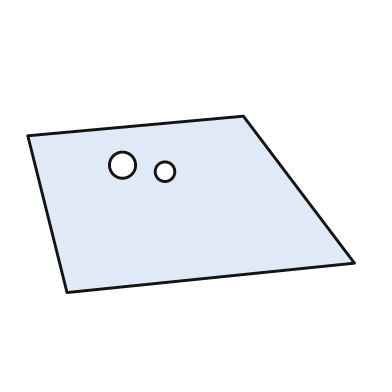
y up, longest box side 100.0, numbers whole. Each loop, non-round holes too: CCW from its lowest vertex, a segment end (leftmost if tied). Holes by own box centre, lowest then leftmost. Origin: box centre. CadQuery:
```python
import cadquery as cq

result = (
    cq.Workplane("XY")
    .moveTo(-38.0, -27.0)
    .lineTo(50.0, -18.0)
    .lineTo(16.0, 27.0)
    .lineTo(-50.0, 21.0)
    .close()
    .moveTo(-8.0, 10.0)
    .circle(3.0)
    .moveTo(-21.0, 12.0)
    .circle(4.0)
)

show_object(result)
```